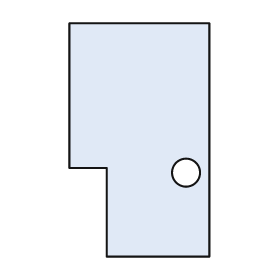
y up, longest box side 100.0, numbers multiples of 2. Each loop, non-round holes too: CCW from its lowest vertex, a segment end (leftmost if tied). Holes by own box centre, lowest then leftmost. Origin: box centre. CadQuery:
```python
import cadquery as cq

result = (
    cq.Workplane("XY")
    .moveTo(-14.0, -50.0)
    .lineTo(30.0, -50.0)
    .lineTo(30.0, 50.0)
    .lineTo(-30.0, 50.0)
    .lineTo(-30.0, -12.0)
    .lineTo(-14.0, -12.0)
    .close()
    .moveTo(20.0, -14.0)
    .circle(6.0)
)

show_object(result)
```